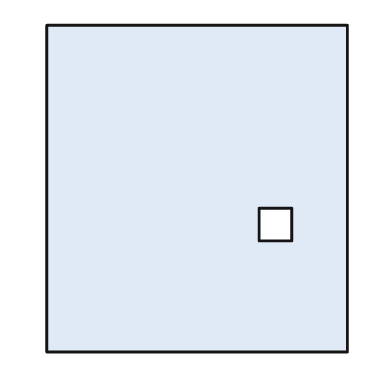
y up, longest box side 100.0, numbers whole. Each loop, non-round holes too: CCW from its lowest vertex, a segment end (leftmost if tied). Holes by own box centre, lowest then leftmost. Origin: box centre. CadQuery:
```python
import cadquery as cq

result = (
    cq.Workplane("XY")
    .moveTo(-46.0, -50.0)
    .lineTo(46.0, -50.0)
    .lineTo(46.0, 50.0)
    .lineTo(-46.0, 50.0)
    .close()
    .moveTo(19.0, -16.0)
    .lineTo(29.0, -16.0)
    .lineTo(29.0, -6.0)
    .lineTo(19.0, -6.0)
    .close()
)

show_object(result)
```